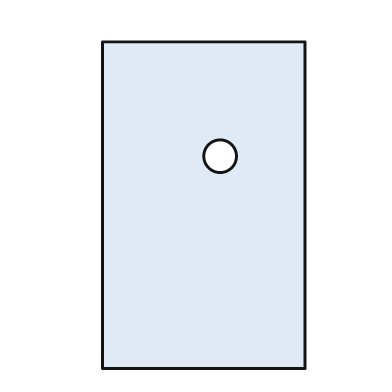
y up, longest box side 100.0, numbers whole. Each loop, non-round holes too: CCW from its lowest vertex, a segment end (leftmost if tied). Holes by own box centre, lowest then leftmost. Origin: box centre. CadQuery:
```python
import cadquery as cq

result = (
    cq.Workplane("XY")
    .moveTo(-31.0, -50.0)
    .lineTo(31.0, -50.0)
    .lineTo(31.0, 50.0)
    .lineTo(-31.0, 50.0)
    .close()
    .moveTo(5.0, 15.0)
    .circle(5.0)
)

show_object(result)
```